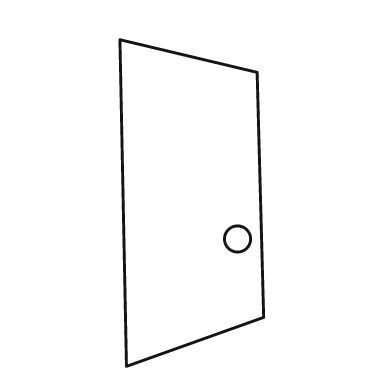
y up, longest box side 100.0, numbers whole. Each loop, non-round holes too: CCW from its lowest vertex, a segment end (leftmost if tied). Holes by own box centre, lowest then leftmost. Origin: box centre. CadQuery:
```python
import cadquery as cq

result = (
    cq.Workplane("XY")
    .moveTo(-20.0, -50.0)
    .lineTo(22.0, -35.0)
    .lineTo(20.0, 40.0)
    .lineTo(-22.0, 50.0)
    .close()
    .moveTo(14.0, -11.0)
    .circle(4.0)
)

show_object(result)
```